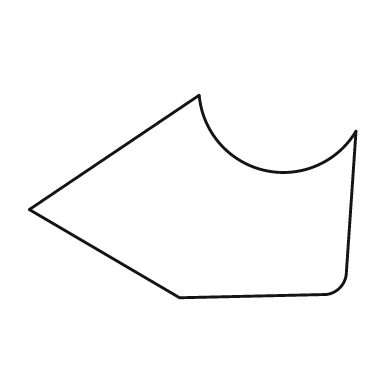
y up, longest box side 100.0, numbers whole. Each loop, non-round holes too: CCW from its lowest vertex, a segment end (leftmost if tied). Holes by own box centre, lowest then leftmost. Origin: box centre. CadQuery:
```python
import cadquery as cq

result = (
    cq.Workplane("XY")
    .moveTo(-4.0, -31.0)
    .lineTo(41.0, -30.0)
    .threePointArc((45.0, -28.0), (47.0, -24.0))
    .lineTo(50.0, 20.0)
    .threePointArc((22.0, 8.0), (2.0, 31.0))
    .lineTo(-50.0, -4.0)
    .close()
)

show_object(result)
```